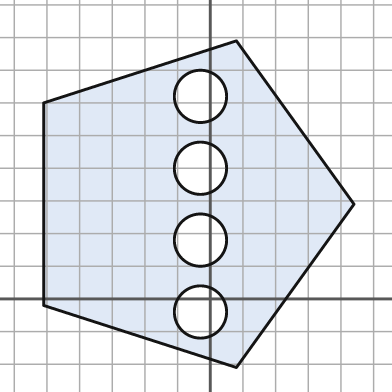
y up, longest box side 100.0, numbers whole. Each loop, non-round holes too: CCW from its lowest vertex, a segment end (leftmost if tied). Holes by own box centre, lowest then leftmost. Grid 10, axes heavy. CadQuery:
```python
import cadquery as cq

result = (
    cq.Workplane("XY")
    .moveTo(8.0, -21.0)
    .lineTo(44.0, 29.0)
    .lineTo(8.0, 79.0)
    .lineTo(-51.0, 60.0)
    .lineTo(-51.0, -2.0)
    .close()
    .moveTo(-3.0, -4.0)
    .circle(8.0)
    .moveTo(-3.0, 18.0)
    .circle(8.0)
    .moveTo(-3.0, 40.0)
    .circle(8.0)
    .moveTo(-3.0, 62.0)
    .circle(8.0)
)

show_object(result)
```